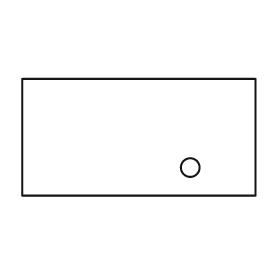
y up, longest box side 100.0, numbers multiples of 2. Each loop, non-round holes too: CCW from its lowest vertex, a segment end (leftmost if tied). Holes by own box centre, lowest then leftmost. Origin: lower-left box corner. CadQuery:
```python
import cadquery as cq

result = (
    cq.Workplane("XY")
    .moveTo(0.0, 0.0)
    .lineTo(100.0, 0.0)
    .lineTo(100.0, 50.0)
    .lineTo(0.0, 50.0)
    .close()
    .moveTo(72.0, 12.0)
    .circle(4.0)
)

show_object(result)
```